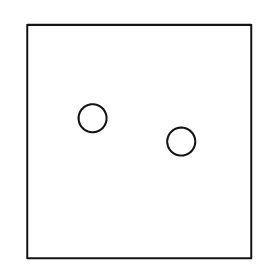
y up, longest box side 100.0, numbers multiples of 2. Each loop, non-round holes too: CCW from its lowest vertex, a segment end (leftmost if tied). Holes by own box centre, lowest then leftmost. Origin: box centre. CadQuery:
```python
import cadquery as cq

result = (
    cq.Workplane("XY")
    .moveTo(-48.0, -50.0)
    .lineTo(48.0, -50.0)
    .lineTo(48.0, 50.0)
    .lineTo(-48.0, 50.0)
    .close()
    .moveTo(18.0, 0.0)
    .circle(6.0)
    .moveTo(-20.0, 10.0)
    .circle(6.0)
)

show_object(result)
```